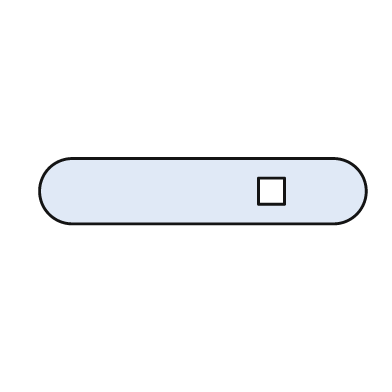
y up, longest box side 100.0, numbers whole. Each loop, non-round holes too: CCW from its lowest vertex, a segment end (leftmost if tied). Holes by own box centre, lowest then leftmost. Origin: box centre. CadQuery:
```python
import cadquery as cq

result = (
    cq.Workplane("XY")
    .moveTo(-40.0, -10.0)
    .lineTo(40.0, -10.0)
    .threePointArc((50.0, 0.0), (40.0, 10.0))
    .lineTo(-40.0, 10.0)
    .threePointArc((-50.0, 0.0), (-40.0, -10.0))
    .close()
    .moveTo(17.0, -4.0)
    .lineTo(25.0, -4.0)
    .lineTo(25.0, 4.0)
    .lineTo(17.0, 4.0)
    .close()
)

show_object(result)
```